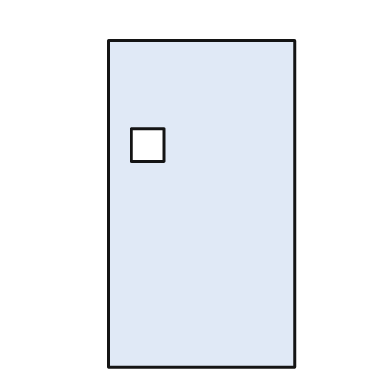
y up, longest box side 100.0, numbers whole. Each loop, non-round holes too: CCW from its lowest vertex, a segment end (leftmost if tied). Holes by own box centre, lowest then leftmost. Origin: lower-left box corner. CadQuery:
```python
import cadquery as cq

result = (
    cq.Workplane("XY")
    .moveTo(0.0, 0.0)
    .lineTo(57.0, 0.0)
    .lineTo(57.0, 100.0)
    .lineTo(0.0, 100.0)
    .close()
    .moveTo(7.0, 63.0)
    .lineTo(17.0, 63.0)
    .lineTo(17.0, 73.0)
    .lineTo(7.0, 73.0)
    .close()
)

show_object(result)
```